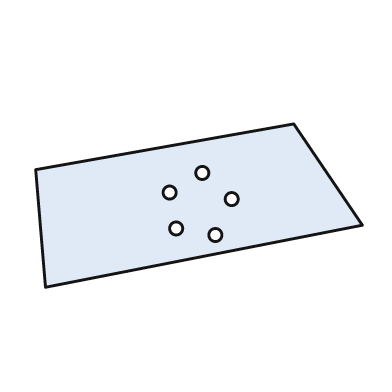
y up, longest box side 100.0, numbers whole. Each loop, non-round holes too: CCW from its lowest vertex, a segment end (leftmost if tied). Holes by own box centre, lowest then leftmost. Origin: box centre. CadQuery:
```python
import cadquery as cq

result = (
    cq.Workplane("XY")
    .moveTo(-47.0, -25.0)
    .lineTo(50.0, -6.0)
    .lineTo(29.0, 25.0)
    .lineTo(-50.0, 11.0)
    .close()
    .moveTo(5.0, -9.0)
    .circle(2.0)
    .moveTo(-7.0, -7.0)
    .circle(2.0)
    .moveTo(10.0, 2.0)
    .circle(2.0)
    .moveTo(-9.0, 4.0)
    .circle(2.0)
    .moveTo(1.0, 10.0)
    .circle(2.0)
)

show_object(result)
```